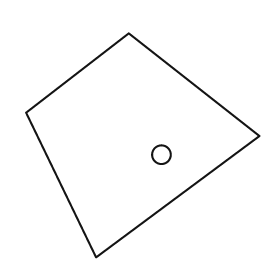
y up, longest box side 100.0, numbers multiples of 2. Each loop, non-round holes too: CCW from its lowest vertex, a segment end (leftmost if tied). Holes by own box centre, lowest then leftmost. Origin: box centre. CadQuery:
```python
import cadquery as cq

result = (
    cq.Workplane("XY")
    .moveTo(-20.0, -48.0)
    .lineTo(50.0, 4.0)
    .lineTo(-6.0, 48.0)
    .lineTo(-50.0, 14.0)
    .close()
    .moveTo(8.0, -4.0)
    .circle(4.0)
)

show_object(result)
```